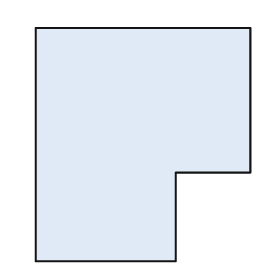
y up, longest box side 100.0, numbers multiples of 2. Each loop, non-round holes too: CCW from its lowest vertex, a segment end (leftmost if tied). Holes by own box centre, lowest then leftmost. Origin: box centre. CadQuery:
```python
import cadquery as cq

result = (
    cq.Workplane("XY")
    .moveTo(-46.0, -50.0)
    .lineTo(14.0, -50.0)
    .lineTo(14.0, -12.0)
    .lineTo(46.0, -12.0)
    .lineTo(46.0, 50.0)
    .lineTo(-46.0, 50.0)
    .close()
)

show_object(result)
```